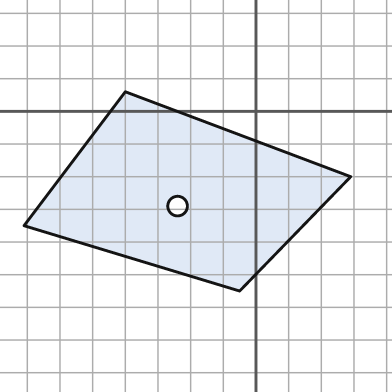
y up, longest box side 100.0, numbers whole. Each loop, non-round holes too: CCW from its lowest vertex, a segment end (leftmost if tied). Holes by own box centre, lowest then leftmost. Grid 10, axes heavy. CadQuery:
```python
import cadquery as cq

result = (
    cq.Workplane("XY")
    .moveTo(-5.0, -55.0)
    .lineTo(29.0, -20.0)
    .lineTo(-40.0, 6.0)
    .lineTo(-71.0, -35.0)
    .close()
    .moveTo(-24.0, -29.0)
    .circle(3.0)
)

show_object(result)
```